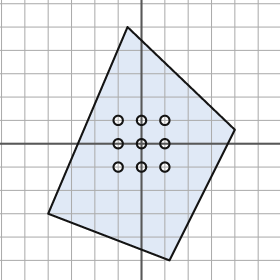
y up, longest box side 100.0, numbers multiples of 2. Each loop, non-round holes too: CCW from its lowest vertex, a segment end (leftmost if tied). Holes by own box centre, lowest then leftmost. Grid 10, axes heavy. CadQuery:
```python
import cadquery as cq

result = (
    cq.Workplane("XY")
    .moveTo(12.0, -50.0)
    .lineTo(40.0, 6.0)
    .lineTo(-6.0, 50.0)
    .lineTo(-40.0, -30.0)
    .close()
    .moveTo(-10.0, -10.0)
    .circle(2.0)
    .moveTo(0.0, -10.0)
    .circle(2.0)
    .moveTo(10.0, -10.0)
    .circle(2.0)
    .moveTo(-10.0, 0.0)
    .circle(2.0)
    .moveTo(0.0, 0.0)
    .circle(2.0)
    .moveTo(10.0, 0.0)
    .circle(2.0)
    .moveTo(-10.0, 10.0)
    .circle(2.0)
    .moveTo(0.0, 10.0)
    .circle(2.0)
    .moveTo(10.0, 10.0)
    .circle(2.0)
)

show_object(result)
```